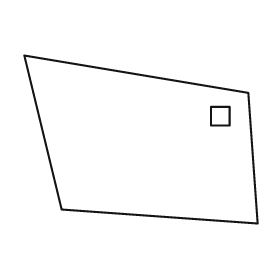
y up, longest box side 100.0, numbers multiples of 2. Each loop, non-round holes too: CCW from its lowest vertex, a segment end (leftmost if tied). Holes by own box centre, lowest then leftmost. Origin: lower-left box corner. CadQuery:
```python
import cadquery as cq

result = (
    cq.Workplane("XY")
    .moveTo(100.0, 0.0)
    .lineTo(96.0, 56.0)
    .lineTo(0.0, 72.0)
    .lineTo(16.0, 6.0)
    .close()
    .moveTo(80.0, 42.0)
    .lineTo(88.0, 42.0)
    .lineTo(88.0, 50.0)
    .lineTo(80.0, 50.0)
    .close()
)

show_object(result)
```